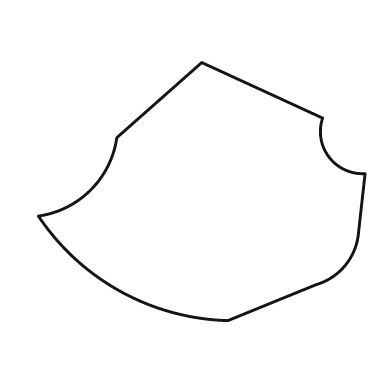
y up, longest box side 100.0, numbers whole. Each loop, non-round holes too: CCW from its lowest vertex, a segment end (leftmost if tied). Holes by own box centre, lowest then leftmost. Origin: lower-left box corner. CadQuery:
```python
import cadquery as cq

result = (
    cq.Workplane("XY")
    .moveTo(58.0, 0.0)
    .lineTo(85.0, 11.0)
    .threePointArc((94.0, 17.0), (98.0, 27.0))
    .lineTo(100.0, 45.0)
    .threePointArc((89.0, 50.0), (87.0, 62.0))
    .lineTo(50.0, 79.0)
    .lineTo(24.0, 56.0)
    .threePointArc((16.0, 40.0), (0.0, 32.0))
    .threePointArc((25.0, 9.0), (58.0, 0.0))
    .close()
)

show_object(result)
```